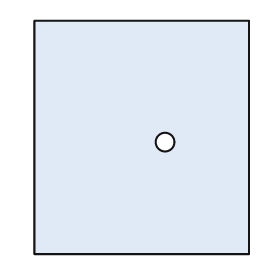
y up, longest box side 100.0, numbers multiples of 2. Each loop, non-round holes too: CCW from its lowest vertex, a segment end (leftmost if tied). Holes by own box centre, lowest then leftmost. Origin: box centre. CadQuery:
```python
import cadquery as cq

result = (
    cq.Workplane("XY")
    .moveTo(-46.0, -50.0)
    .lineTo(46.0, -50.0)
    .lineTo(46.0, 50.0)
    .lineTo(-46.0, 50.0)
    .close()
    .moveTo(10.0, -2.0)
    .circle(4.0)
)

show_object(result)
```